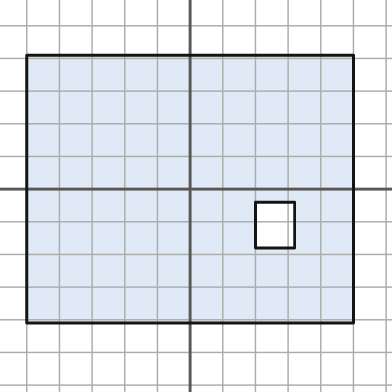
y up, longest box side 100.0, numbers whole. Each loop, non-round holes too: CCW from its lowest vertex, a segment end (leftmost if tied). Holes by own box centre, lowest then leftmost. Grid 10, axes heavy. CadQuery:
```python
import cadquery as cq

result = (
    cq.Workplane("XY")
    .moveTo(-50.0, -41.0)
    .lineTo(50.0, -41.0)
    .lineTo(50.0, 41.0)
    .lineTo(-50.0, 41.0)
    .close()
    .moveTo(20.0, -18.0)
    .lineTo(32.0, -18.0)
    .lineTo(32.0, -4.0)
    .lineTo(20.0, -4.0)
    .close()
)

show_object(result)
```